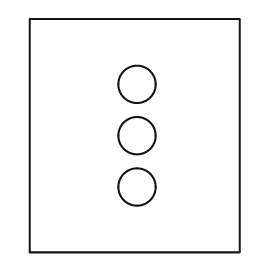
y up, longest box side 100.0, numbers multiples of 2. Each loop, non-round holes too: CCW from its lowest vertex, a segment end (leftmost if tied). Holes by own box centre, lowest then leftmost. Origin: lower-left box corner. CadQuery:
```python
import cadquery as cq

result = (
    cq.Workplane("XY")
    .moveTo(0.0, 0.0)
    .lineTo(90.0, 0.0)
    .lineTo(90.0, 100.0)
    .lineTo(0.0, 100.0)
    .close()
    .moveTo(46.0, 28.0)
    .circle(8.0)
    .moveTo(46.0, 50.0)
    .circle(8.0)
    .moveTo(46.0, 72.0)
    .circle(8.0)
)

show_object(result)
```